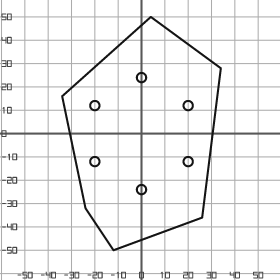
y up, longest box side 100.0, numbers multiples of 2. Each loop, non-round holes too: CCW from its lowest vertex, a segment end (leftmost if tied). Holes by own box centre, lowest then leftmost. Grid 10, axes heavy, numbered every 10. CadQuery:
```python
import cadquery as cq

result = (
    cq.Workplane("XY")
    .moveTo(-12.0, -50.0)
    .lineTo(26.0, -36.0)
    .lineTo(34.0, 28.0)
    .lineTo(4.0, 50.0)
    .lineTo(-34.0, 16.0)
    .lineTo(-24.0, -32.0)
    .close()
    .moveTo(0.0, -24.0)
    .circle(2.0)
    .moveTo(-20.0, -12.0)
    .circle(2.0)
    .moveTo(20.0, -12.0)
    .circle(2.0)
    .moveTo(-20.0, 12.0)
    .circle(2.0)
    .moveTo(20.0, 12.0)
    .circle(2.0)
    .moveTo(0.0, 24.0)
    .circle(2.0)
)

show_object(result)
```